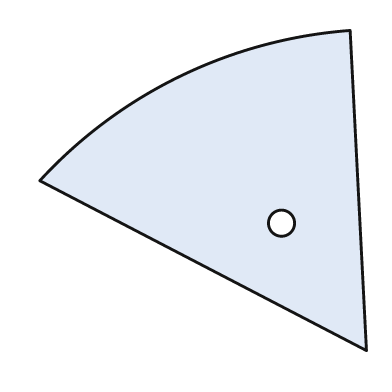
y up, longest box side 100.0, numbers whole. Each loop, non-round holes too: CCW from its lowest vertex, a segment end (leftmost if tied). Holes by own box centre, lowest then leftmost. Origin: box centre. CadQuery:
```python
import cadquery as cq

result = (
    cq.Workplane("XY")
    .moveTo(50.0, -49.0)
    .lineTo(45.0, 49.0)
    .threePointArc((-7.0, 35.0), (-50.0, 3.0))
    .close()
    .moveTo(24.0, -10.0)
    .circle(4.0)
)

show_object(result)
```